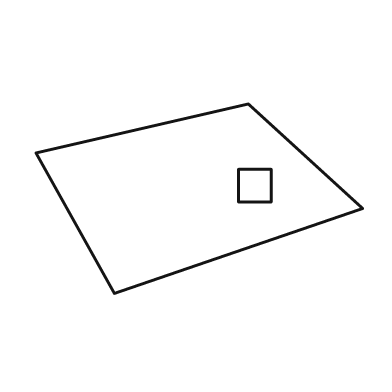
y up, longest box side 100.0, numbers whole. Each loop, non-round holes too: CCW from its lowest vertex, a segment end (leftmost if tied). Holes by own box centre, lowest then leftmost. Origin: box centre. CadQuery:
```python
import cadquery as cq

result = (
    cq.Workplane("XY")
    .moveTo(-26.0, -29.0)
    .lineTo(50.0, -3.0)
    .lineTo(15.0, 29.0)
    .lineTo(-50.0, 14.0)
    .close()
    .moveTo(12.0, -1.0)
    .lineTo(22.0, -1.0)
    .lineTo(22.0, 9.0)
    .lineTo(12.0, 9.0)
    .close()
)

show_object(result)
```